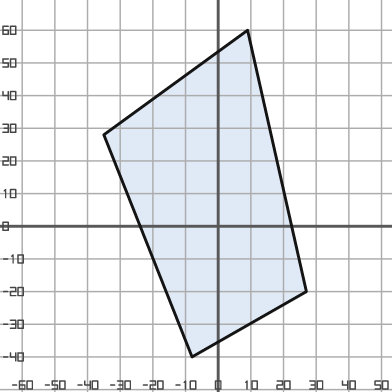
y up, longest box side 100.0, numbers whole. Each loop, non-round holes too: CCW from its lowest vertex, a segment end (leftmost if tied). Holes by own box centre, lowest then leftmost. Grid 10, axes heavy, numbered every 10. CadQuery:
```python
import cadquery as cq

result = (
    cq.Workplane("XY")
    .moveTo(-8.0, -40.0)
    .lineTo(27.0, -20.0)
    .lineTo(9.0, 60.0)
    .lineTo(-35.0, 28.0)
    .close()
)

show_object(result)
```